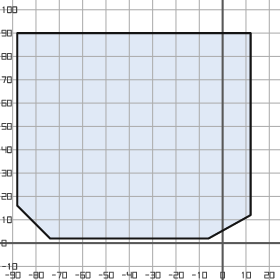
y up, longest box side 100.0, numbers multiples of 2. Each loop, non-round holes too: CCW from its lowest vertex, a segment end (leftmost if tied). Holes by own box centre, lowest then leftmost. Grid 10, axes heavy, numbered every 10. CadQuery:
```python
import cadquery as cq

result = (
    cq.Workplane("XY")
    .moveTo(-74.0, 2.0)
    .lineTo(-6.0, 2.0)
    .lineTo(12.0, 12.0)
    .lineTo(12.0, 90.0)
    .lineTo(-88.0, 90.0)
    .lineTo(-88.0, 16.0)
    .close()
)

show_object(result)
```